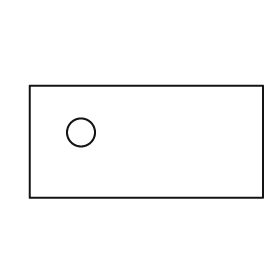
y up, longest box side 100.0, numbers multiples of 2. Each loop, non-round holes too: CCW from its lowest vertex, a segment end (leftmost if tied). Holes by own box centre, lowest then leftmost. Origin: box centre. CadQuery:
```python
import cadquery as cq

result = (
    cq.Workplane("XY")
    .moveTo(-50.0, -24.0)
    .lineTo(50.0, -24.0)
    .lineTo(50.0, 24.0)
    .lineTo(-50.0, 24.0)
    .close()
    .moveTo(-28.0, 4.0)
    .circle(6.0)
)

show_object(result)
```